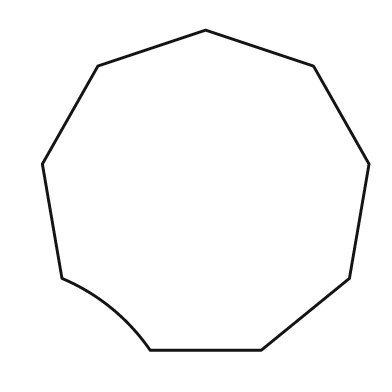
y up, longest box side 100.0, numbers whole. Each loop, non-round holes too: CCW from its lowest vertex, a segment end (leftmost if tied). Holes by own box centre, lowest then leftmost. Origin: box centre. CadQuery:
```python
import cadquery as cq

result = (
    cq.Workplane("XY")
    .moveTo(-17.0, -49.0)
    .lineTo(17.0, -49.0)
    .lineTo(44.0, -27.0)
    .lineTo(50.0, 8.0)
    .lineTo(33.0, 38.0)
    .lineTo(0.0, 49.0)
    .lineTo(-33.0, 38.0)
    .lineTo(-50.0, 8.0)
    .lineTo(-44.0, -27.0)
    .threePointArc((-29.0, -36.0), (-17.0, -49.0))
    .close()
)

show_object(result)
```